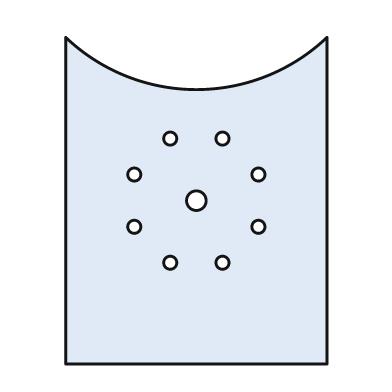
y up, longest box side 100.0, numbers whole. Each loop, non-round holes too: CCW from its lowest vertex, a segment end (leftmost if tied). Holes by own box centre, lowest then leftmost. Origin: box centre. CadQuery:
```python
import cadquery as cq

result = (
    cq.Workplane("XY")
    .moveTo(-40.0, -50.0)
    .lineTo(40.0, -50.0)
    .lineTo(40.0, 50.0)
    .threePointArc((0.0, 34.0), (-40.0, 50.0))
    .close()
    .moveTo(-8.0, -19.0)
    .circle(2.0)
    .moveTo(8.0, -19.0)
    .circle(2.0)
    .moveTo(-19.0, -8.0)
    .circle(2.0)
    .moveTo(19.0, -8.0)
    .circle(2.0)
    .moveTo(0.0, 0.0)
    .circle(3.0)
    .moveTo(-19.0, 8.0)
    .circle(2.0)
    .moveTo(19.0, 8.0)
    .circle(2.0)
    .moveTo(-8.0, 19.0)
    .circle(2.0)
    .moveTo(8.0, 19.0)
    .circle(2.0)
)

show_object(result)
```